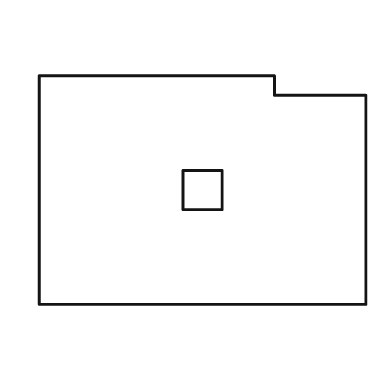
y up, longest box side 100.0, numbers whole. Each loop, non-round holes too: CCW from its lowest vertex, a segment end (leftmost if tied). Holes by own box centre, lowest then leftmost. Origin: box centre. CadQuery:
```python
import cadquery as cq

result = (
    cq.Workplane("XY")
    .moveTo(-50.0, -35.0)
    .lineTo(50.0, -35.0)
    .lineTo(50.0, 29.0)
    .lineTo(22.0, 29.0)
    .lineTo(22.0, 35.0)
    .lineTo(-50.0, 35.0)
    .close()
    .moveTo(-6.0, -6.0)
    .lineTo(6.0, -6.0)
    .lineTo(6.0, 6.0)
    .lineTo(-6.0, 6.0)
    .close()
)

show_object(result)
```